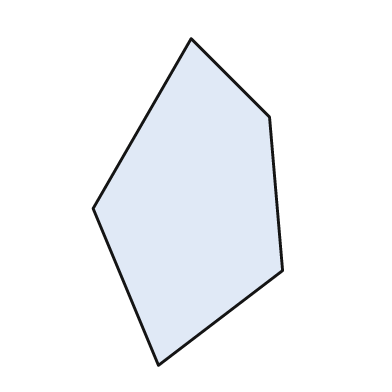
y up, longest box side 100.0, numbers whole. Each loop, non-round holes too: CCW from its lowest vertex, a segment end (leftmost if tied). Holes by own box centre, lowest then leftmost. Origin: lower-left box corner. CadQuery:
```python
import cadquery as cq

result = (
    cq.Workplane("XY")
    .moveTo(20.0, 0.0)
    .lineTo(58.0, 29.0)
    .lineTo(54.0, 76.0)
    .lineTo(30.0, 100.0)
    .lineTo(0.0, 48.0)
    .close()
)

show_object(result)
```